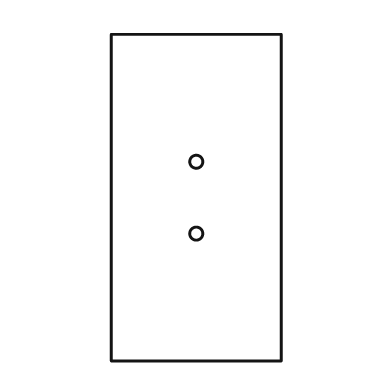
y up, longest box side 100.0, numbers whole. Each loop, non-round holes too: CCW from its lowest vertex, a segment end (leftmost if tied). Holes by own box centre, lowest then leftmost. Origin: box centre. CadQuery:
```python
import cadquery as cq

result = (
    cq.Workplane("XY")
    .moveTo(-26.0, -50.0)
    .lineTo(26.0, -50.0)
    .lineTo(26.0, 50.0)
    .lineTo(-26.0, 50.0)
    .close()
    .moveTo(0.0, -11.0)
    .circle(2.0)
    .moveTo(0.0, 11.0)
    .circle(2.0)
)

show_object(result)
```